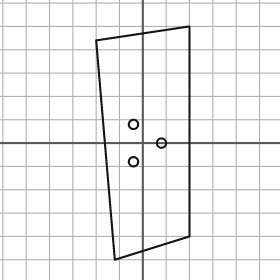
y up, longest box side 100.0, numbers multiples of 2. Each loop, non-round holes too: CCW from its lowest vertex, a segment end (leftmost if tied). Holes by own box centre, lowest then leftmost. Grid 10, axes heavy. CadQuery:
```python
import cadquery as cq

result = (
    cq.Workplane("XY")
    .moveTo(-12.0, -50.0)
    .lineTo(20.0, -40.0)
    .lineTo(20.0, 50.0)
    .lineTo(-20.0, 44.0)
    .close()
    .moveTo(-4.0, -8.0)
    .circle(2.0)
    .moveTo(8.0, 0.0)
    .circle(2.0)
    .moveTo(-4.0, 8.0)
    .circle(2.0)
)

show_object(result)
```